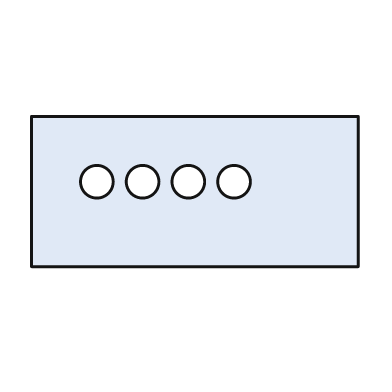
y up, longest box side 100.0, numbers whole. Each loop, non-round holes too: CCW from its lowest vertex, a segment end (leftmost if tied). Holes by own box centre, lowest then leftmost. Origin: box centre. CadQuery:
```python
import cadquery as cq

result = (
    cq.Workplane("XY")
    .moveTo(-50.0, -23.0)
    .lineTo(50.0, -23.0)
    .lineTo(50.0, 23.0)
    .lineTo(-50.0, 23.0)
    .close()
    .moveTo(-30.0, 3.0)
    .circle(5.0)
    .moveTo(-16.0, 3.0)
    .circle(5.0)
    .moveTo(-2.0, 3.0)
    .circle(5.0)
    .moveTo(12.0, 3.0)
    .circle(5.0)
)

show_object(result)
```